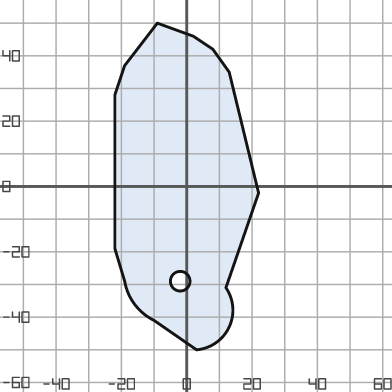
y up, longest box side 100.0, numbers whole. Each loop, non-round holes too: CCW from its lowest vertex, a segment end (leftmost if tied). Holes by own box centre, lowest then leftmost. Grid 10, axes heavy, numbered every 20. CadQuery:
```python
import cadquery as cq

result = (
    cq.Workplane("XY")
    .moveTo(3.0, -50.0)
    .threePointArc((13.0, -43.0), (12.0, -31.0))
    .lineTo(22.0, -2.0)
    .lineTo(13.0, 35.0)
    .lineTo(8.0, 42.0)
    .lineTo(2.0, 46.0)
    .lineTo(-9.0, 50.0)
    .lineTo(-19.0, 37.0)
    .lineTo(-22.0, 28.0)
    .lineTo(-22.0, -19.0)
    .lineTo(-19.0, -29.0)
    .threePointArc((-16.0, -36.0), (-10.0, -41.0))
    .close()
    .moveTo(-2.0, -29.0)
    .circle(3.0)
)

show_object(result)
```